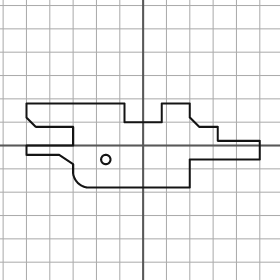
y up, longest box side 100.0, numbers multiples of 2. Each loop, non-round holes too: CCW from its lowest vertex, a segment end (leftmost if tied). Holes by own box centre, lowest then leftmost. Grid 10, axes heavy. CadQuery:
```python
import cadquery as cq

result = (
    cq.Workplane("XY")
    .moveTo(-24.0, -18.0)
    .lineTo(20.0, -18.0)
    .lineTo(20.0, -6.0)
    .lineTo(50.0, -6.0)
    .lineTo(50.0, 2.0)
    .lineTo(32.0, 2.0)
    .lineTo(32.0, 8.0)
    .lineTo(24.0, 8.0)
    .lineTo(20.0, 12.0)
    .lineTo(20.0, 18.0)
    .lineTo(8.0, 18.0)
    .lineTo(8.0, 10.0)
    .lineTo(-8.0, 10.0)
    .lineTo(-8.0, 18.0)
    .lineTo(-50.0, 18.0)
    .lineTo(-50.0, 12.0)
    .lineTo(-46.0, 8.0)
    .lineTo(-30.0, 8.0)
    .lineTo(-30.0, 0.0)
    .lineTo(-50.0, 0.0)
    .lineTo(-50.0, -4.0)
    .lineTo(-36.0, -4.0)
    .lineTo(-30.0, -8.0)
    .lineTo(-30.0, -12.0)
    .threePointArc((-28.0, -16.0), (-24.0, -18.0))
    .close()
    .moveTo(-16.0, -6.0)
    .circle(2.0)
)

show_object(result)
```